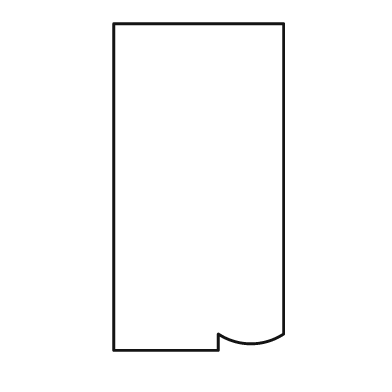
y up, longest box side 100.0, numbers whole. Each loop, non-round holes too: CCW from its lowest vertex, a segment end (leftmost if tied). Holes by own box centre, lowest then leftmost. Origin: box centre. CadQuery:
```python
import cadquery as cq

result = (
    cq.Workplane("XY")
    .moveTo(-26.0, -50.0)
    .lineTo(6.0, -50.0)
    .lineTo(6.0, -45.0)
    .threePointArc((16.0, -48.0), (26.0, -45.0))
    .lineTo(26.0, 50.0)
    .lineTo(-26.0, 50.0)
    .close()
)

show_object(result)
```